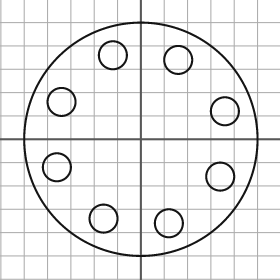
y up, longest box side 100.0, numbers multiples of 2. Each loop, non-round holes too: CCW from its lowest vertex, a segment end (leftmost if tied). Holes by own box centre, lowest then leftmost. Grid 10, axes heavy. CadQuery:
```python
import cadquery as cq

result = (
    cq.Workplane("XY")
    .moveTo(0.0, 0.0)
    .circle(50.0)
    .moveTo(12.0, -36.0)
    .circle(6.0)
    .moveTo(-16.0, -34.0)
    .circle(6.0)
    .moveTo(34.0, -16.0)
    .circle(6.0)
    .moveTo(-36.0, -12.0)
    .circle(6.0)
    .moveTo(36.0, 12.0)
    .circle(6.0)
    .moveTo(-34.0, 16.0)
    .circle(6.0)
    .moveTo(16.0, 34.0)
    .circle(6.0)
    .moveTo(-12.0, 36.0)
    .circle(6.0)
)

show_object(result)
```